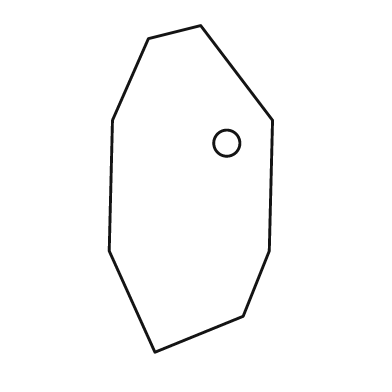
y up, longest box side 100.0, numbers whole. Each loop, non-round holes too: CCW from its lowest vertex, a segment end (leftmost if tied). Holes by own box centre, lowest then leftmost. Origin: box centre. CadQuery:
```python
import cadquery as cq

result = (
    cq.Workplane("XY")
    .moveTo(-11.0, -50.0)
    .lineTo(16.0, -39.0)
    .lineTo(24.0, -19.0)
    .lineTo(25.0, 21.0)
    .lineTo(3.0, 50.0)
    .lineTo(-13.0, 46.0)
    .lineTo(-24.0, 21.0)
    .lineTo(-25.0, -19.0)
    .close()
    .moveTo(11.0, 14.0)
    .circle(4.0)
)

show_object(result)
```